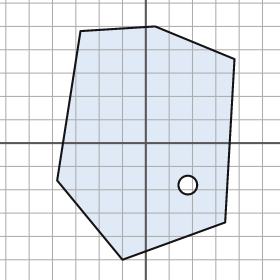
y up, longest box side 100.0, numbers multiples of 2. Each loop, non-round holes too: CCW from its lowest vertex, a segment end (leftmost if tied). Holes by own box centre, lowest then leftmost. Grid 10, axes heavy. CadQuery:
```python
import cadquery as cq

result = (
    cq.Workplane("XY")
    .moveTo(-10.0, -50.0)
    .lineTo(34.0, -34.0)
    .lineTo(38.0, 36.0)
    .lineTo(4.0, 50.0)
    .lineTo(-28.0, 48.0)
    .lineTo(-38.0, -16.0)
    .close()
    .moveTo(18.0, -18.0)
    .circle(4.0)
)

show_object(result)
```